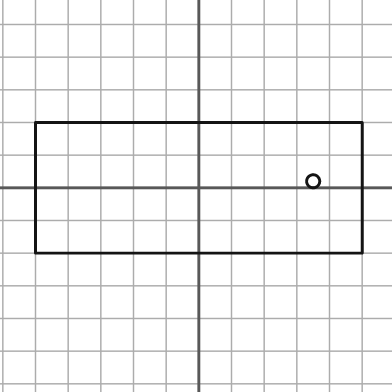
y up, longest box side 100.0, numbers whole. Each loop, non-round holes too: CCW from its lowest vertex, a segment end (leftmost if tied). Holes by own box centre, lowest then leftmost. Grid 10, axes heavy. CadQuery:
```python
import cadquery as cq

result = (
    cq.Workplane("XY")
    .moveTo(-50.0, -20.0)
    .lineTo(50.0, -20.0)
    .lineTo(50.0, 20.0)
    .lineTo(-50.0, 20.0)
    .close()
    .moveTo(35.0, 2.0)
    .circle(2.0)
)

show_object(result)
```